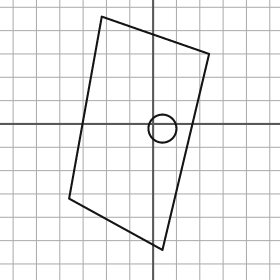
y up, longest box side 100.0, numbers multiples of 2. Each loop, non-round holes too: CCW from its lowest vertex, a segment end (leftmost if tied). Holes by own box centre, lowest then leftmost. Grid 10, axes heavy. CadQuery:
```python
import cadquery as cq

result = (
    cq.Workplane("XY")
    .moveTo(4.0, -54.0)
    .lineTo(24.0, 30.0)
    .lineTo(-22.0, 46.0)
    .lineTo(-36.0, -32.0)
    .close()
    .moveTo(4.0, -2.0)
    .circle(6.0)
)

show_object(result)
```